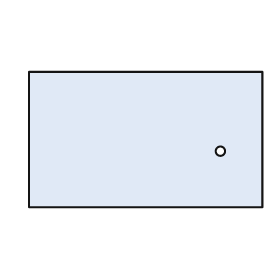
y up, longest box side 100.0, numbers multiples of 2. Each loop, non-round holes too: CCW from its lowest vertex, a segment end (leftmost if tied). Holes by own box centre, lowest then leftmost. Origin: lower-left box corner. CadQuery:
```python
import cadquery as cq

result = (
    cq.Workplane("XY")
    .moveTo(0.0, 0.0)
    .lineTo(100.0, 0.0)
    .lineTo(100.0, 58.0)
    .lineTo(0.0, 58.0)
    .close()
    .moveTo(82.0, 24.0)
    .circle(2.0)
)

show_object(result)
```